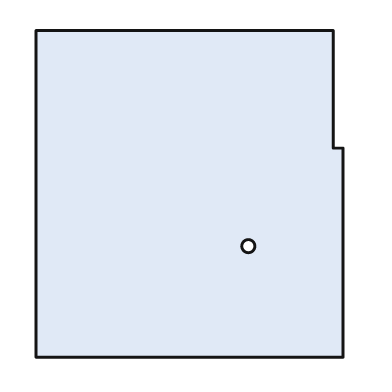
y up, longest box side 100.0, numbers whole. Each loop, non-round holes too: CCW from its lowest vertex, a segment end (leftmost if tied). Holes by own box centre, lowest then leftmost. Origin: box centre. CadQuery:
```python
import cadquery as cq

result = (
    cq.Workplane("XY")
    .moveTo(-47.0, -50.0)
    .lineTo(47.0, -50.0)
    .lineTo(47.0, 14.0)
    .lineTo(44.0, 14.0)
    .lineTo(44.0, 50.0)
    .lineTo(-47.0, 50.0)
    .close()
    .moveTo(18.0, -16.0)
    .circle(2.0)
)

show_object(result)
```